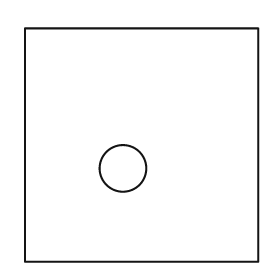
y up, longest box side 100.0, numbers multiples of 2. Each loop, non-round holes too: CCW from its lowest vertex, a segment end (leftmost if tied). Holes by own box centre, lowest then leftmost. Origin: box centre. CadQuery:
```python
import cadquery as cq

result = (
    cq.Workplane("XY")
    .moveTo(-50.0, -50.0)
    .lineTo(50.0, -50.0)
    .lineTo(50.0, 50.0)
    .lineTo(-50.0, 50.0)
    .close()
    .moveTo(-8.0, -10.0)
    .circle(10.0)
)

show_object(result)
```